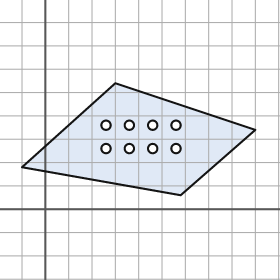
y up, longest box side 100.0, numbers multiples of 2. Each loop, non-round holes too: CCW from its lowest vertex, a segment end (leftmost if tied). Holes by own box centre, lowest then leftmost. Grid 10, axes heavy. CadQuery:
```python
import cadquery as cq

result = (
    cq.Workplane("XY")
    .moveTo(58.0, 6.0)
    .lineTo(90.0, 34.0)
    .lineTo(30.0, 54.0)
    .lineTo(-10.0, 18.0)
    .close()
    .moveTo(26.0, 26.0)
    .circle(2.0)
    .moveTo(36.0, 26.0)
    .circle(2.0)
    .moveTo(46.0, 26.0)
    .circle(2.0)
    .moveTo(56.0, 26.0)
    .circle(2.0)
    .moveTo(26.0, 36.0)
    .circle(2.0)
    .moveTo(36.0, 36.0)
    .circle(2.0)
    .moveTo(46.0, 36.0)
    .circle(2.0)
    .moveTo(56.0, 36.0)
    .circle(2.0)
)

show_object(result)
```